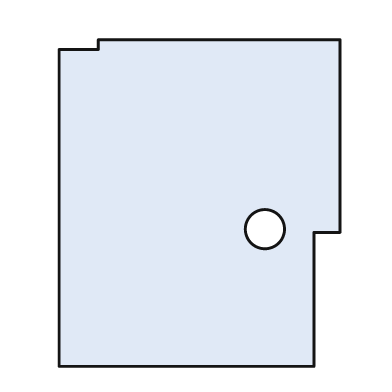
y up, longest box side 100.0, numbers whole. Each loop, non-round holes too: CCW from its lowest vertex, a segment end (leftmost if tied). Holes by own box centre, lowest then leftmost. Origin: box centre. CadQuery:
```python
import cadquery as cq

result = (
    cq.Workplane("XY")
    .moveTo(-43.0, -50.0)
    .lineTo(35.0, -50.0)
    .lineTo(35.0, -9.0)
    .lineTo(43.0, -9.0)
    .lineTo(43.0, 50.0)
    .lineTo(-31.0, 50.0)
    .lineTo(-31.0, 47.0)
    .lineTo(-43.0, 47.0)
    .close()
    .moveTo(20.0, -8.0)
    .circle(6.0)
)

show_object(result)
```